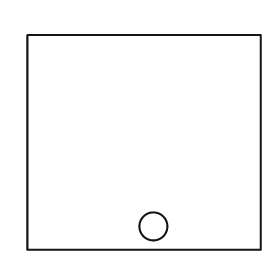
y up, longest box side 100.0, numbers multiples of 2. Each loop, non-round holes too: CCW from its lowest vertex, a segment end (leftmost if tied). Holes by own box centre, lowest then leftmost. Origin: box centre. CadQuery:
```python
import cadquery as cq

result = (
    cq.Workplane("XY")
    .moveTo(-50.0, -46.0)
    .lineTo(50.0, -46.0)
    .lineTo(50.0, 46.0)
    .lineTo(-50.0, 46.0)
    .close()
    .moveTo(4.0, -36.0)
    .circle(6.0)
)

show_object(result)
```